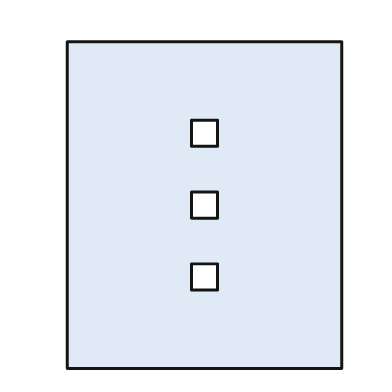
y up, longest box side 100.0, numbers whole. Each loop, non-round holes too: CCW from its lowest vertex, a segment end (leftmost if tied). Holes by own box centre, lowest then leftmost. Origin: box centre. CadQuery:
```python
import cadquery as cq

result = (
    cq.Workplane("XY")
    .moveTo(-42.0, -50.0)
    .lineTo(42.0, -50.0)
    .lineTo(42.0, 50.0)
    .lineTo(-42.0, 50.0)
    .close()
    .moveTo(-4.0, -26.0)
    .lineTo(4.0, -26.0)
    .lineTo(4.0, -18.0)
    .lineTo(-4.0, -18.0)
    .close()
    .moveTo(-4.0, -4.0)
    .lineTo(4.0, -4.0)
    .lineTo(4.0, 4.0)
    .lineTo(-4.0, 4.0)
    .close()
    .moveTo(-4.0, 18.0)
    .lineTo(4.0, 18.0)
    .lineTo(4.0, 26.0)
    .lineTo(-4.0, 26.0)
    .close()
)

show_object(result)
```